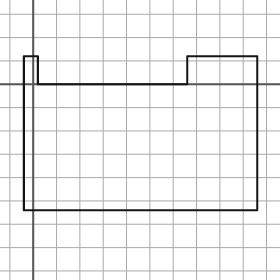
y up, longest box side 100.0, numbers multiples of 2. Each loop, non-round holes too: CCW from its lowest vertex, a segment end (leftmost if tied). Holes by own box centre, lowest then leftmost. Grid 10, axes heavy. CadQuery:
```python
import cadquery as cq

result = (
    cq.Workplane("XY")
    .moveTo(-4.0, -54.0)
    .lineTo(96.0, -54.0)
    .lineTo(96.0, 12.0)
    .lineTo(66.0, 12.0)
    .lineTo(66.0, 0.0)
    .lineTo(2.0, 0.0)
    .lineTo(2.0, 12.0)
    .lineTo(-4.0, 12.0)
    .close()
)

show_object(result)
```